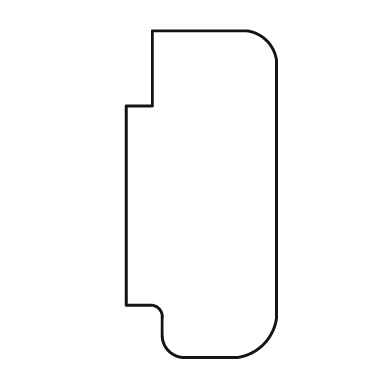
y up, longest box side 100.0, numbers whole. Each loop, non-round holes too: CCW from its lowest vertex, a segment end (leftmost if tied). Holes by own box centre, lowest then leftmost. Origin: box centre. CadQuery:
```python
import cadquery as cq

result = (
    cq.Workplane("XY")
    .moveTo(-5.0, -50.0)
    .lineTo(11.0, -50.0)
    .threePointArc((19.0, -46.0), (23.0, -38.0))
    .lineTo(23.0, 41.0)
    .threePointArc((20.0, 47.0), (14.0, 50.0))
    .lineTo(-15.0, 50.0)
    .lineTo(-15.0, 27.0)
    .lineTo(-23.0, 27.0)
    .lineTo(-23.0, -34.0)
    .lineTo(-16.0, -34.0)
    .threePointArc((-13.0, -35.0), (-12.0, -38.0))
    .lineTo(-12.0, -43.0)
    .threePointArc((-10.0, -48.0), (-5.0, -50.0))
    .close()
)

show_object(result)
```